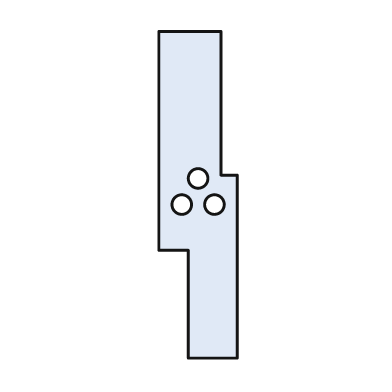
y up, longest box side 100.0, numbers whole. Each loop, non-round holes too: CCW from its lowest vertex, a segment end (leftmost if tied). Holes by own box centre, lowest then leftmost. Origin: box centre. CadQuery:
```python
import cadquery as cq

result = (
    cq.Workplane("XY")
    .moveTo(-3.0, -50.0)
    .lineTo(12.0, -50.0)
    .lineTo(12.0, 6.0)
    .lineTo(7.0, 6.0)
    .lineTo(7.0, 50.0)
    .lineTo(-12.0, 50.0)
    .lineTo(-12.0, -17.0)
    .lineTo(-3.0, -17.0)
    .close()
    .moveTo(-5.0, -3.0)
    .circle(3.0)
    .moveTo(5.0, -3.0)
    .circle(3.0)
    .moveTo(0.0, 5.0)
    .circle(3.0)
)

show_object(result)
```